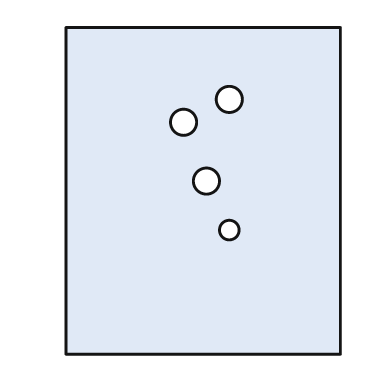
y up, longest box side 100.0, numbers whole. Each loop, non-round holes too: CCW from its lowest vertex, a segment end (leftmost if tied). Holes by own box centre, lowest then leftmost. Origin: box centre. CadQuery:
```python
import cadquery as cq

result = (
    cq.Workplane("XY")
    .moveTo(-42.0, -50.0)
    .lineTo(42.0, -50.0)
    .lineTo(42.0, 50.0)
    .lineTo(-42.0, 50.0)
    .close()
    .moveTo(8.0, -12.0)
    .circle(3.0)
    .moveTo(1.0, 3.0)
    .circle(4.0)
    .moveTo(-6.0, 21.0)
    .circle(4.0)
    .moveTo(8.0, 28.0)
    .circle(4.0)
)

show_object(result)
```